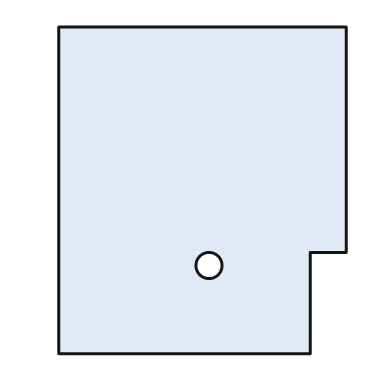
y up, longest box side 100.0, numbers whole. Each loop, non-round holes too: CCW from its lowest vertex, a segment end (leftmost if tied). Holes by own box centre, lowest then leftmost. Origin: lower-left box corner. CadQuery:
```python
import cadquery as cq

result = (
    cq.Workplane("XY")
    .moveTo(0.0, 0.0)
    .lineTo(77.0, 0.0)
    .lineTo(77.0, 31.0)
    .lineTo(88.0, 31.0)
    .lineTo(88.0, 100.0)
    .lineTo(0.0, 100.0)
    .close()
    .moveTo(46.0, 27.0)
    .circle(4.0)
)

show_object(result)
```